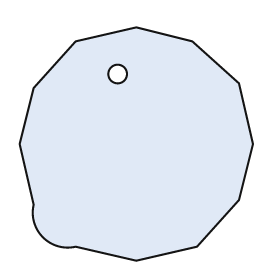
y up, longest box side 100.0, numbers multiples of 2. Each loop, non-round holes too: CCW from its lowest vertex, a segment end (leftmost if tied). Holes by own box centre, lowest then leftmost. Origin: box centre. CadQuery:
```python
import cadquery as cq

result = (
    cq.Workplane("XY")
    .moveTo(0.0, -50.0)
    .lineTo(26.0, -44.0)
    .lineTo(44.0, -24.0)
    .lineTo(50.0, 0.0)
    .lineTo(44.0, 26.0)
    .lineTo(24.0, 44.0)
    .lineTo(0.0, 50.0)
    .lineTo(-26.0, 44.0)
    .lineTo(-44.0, 24.0)
    .lineTo(-50.0, 0.0)
    .lineTo(-44.0, -26.0)
    .threePointArc((-40.0, -40.0), (-26.0, -44.0))
    .close()
    .moveTo(-8.0, 30.0)
    .circle(4.0)
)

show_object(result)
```